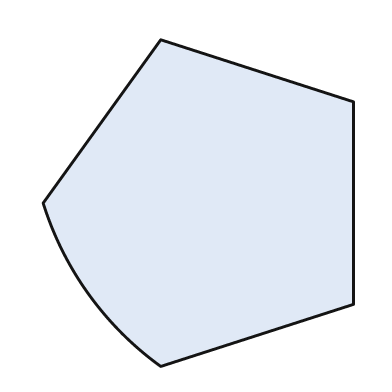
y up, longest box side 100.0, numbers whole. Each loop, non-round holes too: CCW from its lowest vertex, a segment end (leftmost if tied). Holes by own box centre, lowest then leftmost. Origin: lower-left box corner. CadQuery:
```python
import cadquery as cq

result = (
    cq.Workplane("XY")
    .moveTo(36.0, 0.0)
    .lineTo(95.0, 19.0)
    .lineTo(95.0, 81.0)
    .lineTo(36.0, 100.0)
    .lineTo(0.0, 50.0)
    .threePointArc((14.0, 22.0), (36.0, 0.0))
    .close()
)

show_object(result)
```